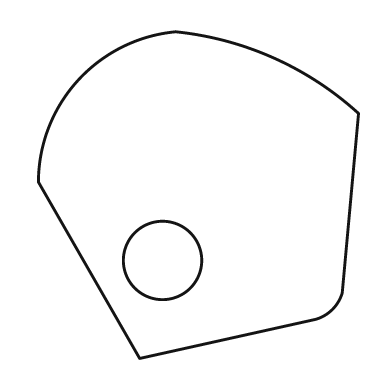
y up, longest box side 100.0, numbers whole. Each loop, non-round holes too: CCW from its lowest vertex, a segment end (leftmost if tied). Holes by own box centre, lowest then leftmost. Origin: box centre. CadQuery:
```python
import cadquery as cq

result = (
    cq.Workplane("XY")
    .moveTo(-18.0, -50.0)
    .lineTo(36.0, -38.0)
    .threePointArc((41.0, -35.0), (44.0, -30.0))
    .lineTo(49.0, 25.0)
    .threePointArc((23.0, 42.0), (-7.0, 50.0))
    .threePointArc((-37.0, 35.0), (-49.0, 4.0))
    .close()
    .moveTo(-11.0, -20.0)
    .circle(12.0)
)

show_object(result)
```